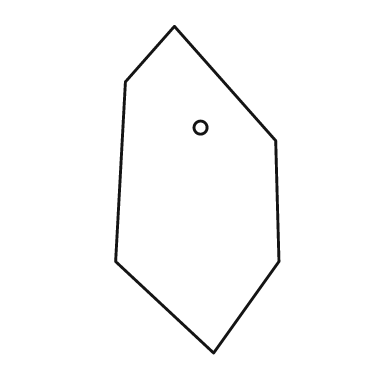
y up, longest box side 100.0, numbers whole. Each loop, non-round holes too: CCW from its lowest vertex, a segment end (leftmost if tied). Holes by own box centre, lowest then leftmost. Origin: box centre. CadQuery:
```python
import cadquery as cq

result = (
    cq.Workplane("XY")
    .moveTo(5.0, -50.0)
    .lineTo(25.0, -22.0)
    .lineTo(24.0, 15.0)
    .lineTo(-7.0, 50.0)
    .lineTo(-22.0, 33.0)
    .lineTo(-25.0, -22.0)
    .close()
    .moveTo(1.0, 19.0)
    .circle(2.0)
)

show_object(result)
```